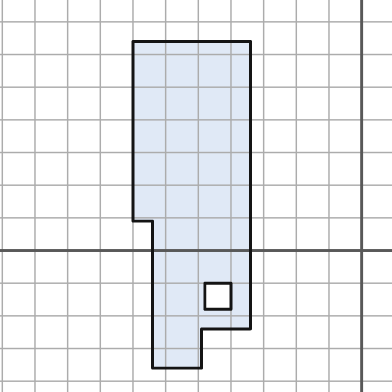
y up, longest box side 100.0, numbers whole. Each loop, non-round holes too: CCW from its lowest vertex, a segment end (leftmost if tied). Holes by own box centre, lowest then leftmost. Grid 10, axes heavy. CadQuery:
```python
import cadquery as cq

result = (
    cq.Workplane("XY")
    .moveTo(-64.0, -36.0)
    .lineTo(-49.0, -36.0)
    .lineTo(-49.0, -24.0)
    .lineTo(-34.0, -24.0)
    .lineTo(-34.0, 64.0)
    .lineTo(-70.0, 64.0)
    .lineTo(-70.0, 9.0)
    .lineTo(-64.0, 9.0)
    .close()
    .moveTo(-48.0, -18.0)
    .lineTo(-40.0, -18.0)
    .lineTo(-40.0, -10.0)
    .lineTo(-48.0, -10.0)
    .close()
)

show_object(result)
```